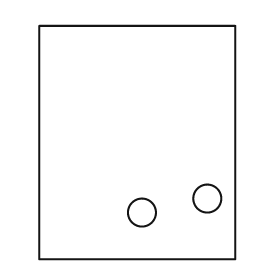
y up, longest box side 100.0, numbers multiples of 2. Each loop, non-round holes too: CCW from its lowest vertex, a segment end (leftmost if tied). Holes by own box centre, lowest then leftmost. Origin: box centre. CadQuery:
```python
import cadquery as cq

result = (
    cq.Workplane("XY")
    .moveTo(-42.0, -50.0)
    .lineTo(42.0, -50.0)
    .lineTo(42.0, 50.0)
    .lineTo(-42.0, 50.0)
    .close()
    .moveTo(2.0, -30.0)
    .circle(6.0)
    .moveTo(30.0, -24.0)
    .circle(6.0)
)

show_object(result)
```